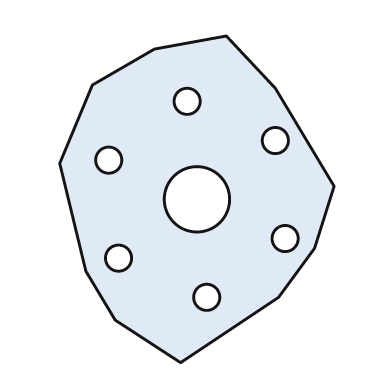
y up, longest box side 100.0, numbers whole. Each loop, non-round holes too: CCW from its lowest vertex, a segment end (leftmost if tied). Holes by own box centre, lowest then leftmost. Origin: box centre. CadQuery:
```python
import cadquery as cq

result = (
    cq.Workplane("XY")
    .moveTo(-5.0, -50.0)
    .lineTo(25.0, -30.0)
    .lineTo(36.0, -15.0)
    .lineTo(42.0, 4.0)
    .lineTo(24.0, 34.0)
    .lineTo(9.0, 50.0)
    .lineTo(-13.0, 46.0)
    .lineTo(-32.0, 35.0)
    .lineTo(-42.0, 11.0)
    .lineTo(-34.0, -22.0)
    .lineTo(-25.0, -37.0)
    .close()
    .moveTo(3.0, -30.0)
    .circle(4.0)
    .moveTo(-24.0, -18.0)
    .circle(4.0)
    .moveTo(27.0, -12.0)
    .circle(4.0)
    .moveTo(0.0, 0.0)
    .circle(10.0)
    .moveTo(-27.0, 12.0)
    .circle(4.0)
    .moveTo(24.0, 18.0)
    .circle(4.0)
    .moveTo(-3.0, 30.0)
    .circle(4.0)
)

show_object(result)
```